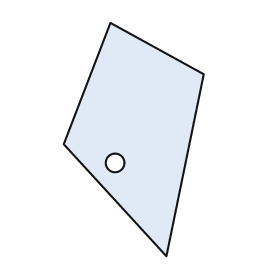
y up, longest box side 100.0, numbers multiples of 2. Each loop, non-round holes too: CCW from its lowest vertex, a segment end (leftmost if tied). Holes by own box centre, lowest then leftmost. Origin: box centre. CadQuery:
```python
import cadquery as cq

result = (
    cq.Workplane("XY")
    .moveTo(14.0, -50.0)
    .lineTo(30.0, 28.0)
    .lineTo(-10.0, 50.0)
    .lineTo(-30.0, -2.0)
    .close()
    .moveTo(-8.0, -10.0)
    .circle(4.0)
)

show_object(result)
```